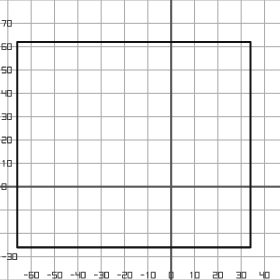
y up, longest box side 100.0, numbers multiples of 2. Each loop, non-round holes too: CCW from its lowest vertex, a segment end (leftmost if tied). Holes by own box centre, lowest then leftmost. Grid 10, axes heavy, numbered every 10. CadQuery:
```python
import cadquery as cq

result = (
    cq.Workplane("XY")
    .moveTo(-66.0, -26.0)
    .lineTo(34.0, -26.0)
    .lineTo(34.0, 62.0)
    .lineTo(-66.0, 62.0)
    .close()
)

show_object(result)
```